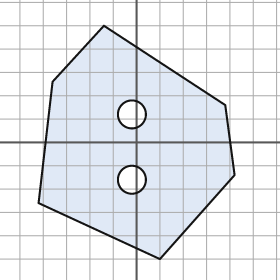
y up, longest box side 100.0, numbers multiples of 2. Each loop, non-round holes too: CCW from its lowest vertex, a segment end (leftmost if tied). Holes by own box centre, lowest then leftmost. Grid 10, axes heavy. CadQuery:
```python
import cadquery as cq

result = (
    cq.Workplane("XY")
    .moveTo(10.0, -50.0)
    .lineTo(42.0, -14.0)
    .lineTo(38.0, 16.0)
    .lineTo(-14.0, 50.0)
    .lineTo(-36.0, 26.0)
    .lineTo(-42.0, -26.0)
    .close()
    .moveTo(-2.0, -16.0)
    .circle(6.0)
    .moveTo(-2.0, 12.0)
    .circle(6.0)
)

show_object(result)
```